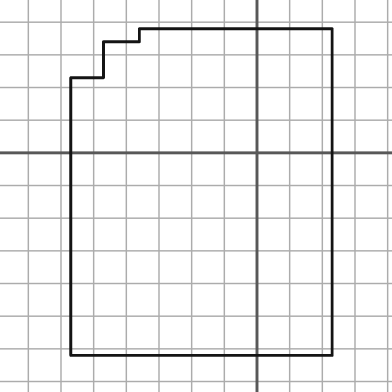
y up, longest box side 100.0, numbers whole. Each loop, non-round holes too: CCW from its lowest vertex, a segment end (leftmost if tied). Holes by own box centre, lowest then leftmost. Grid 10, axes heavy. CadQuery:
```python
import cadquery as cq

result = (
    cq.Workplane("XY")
    .moveTo(-57.0, -62.0)
    .lineTo(23.0, -62.0)
    .lineTo(23.0, 38.0)
    .lineTo(-36.0, 38.0)
    .lineTo(-36.0, 34.0)
    .lineTo(-47.0, 34.0)
    .lineTo(-47.0, 23.0)
    .lineTo(-57.0, 23.0)
    .close()
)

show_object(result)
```